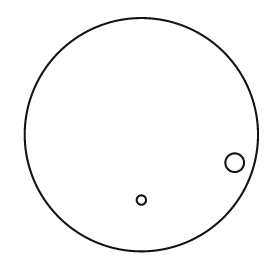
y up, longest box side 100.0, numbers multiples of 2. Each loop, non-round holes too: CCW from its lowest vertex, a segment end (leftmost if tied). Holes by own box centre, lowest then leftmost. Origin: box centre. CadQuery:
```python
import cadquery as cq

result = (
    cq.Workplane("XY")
    .moveTo(0.0, 0.0)
    .circle(50.0)
    .moveTo(0.0, -28.0)
    .circle(2.0)
    .moveTo(40.0, -12.0)
    .circle(4.0)
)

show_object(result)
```